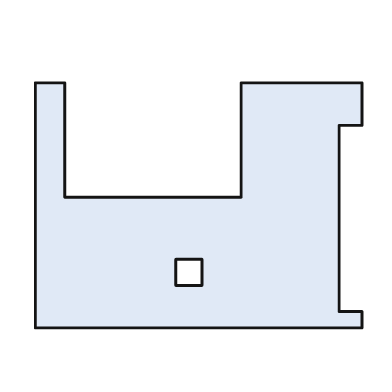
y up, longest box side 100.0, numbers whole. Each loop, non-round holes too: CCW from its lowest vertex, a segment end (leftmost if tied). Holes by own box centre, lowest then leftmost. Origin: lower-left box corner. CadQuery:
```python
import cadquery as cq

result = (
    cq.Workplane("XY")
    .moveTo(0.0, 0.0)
    .lineTo(100.0, 0.0)
    .lineTo(100.0, 5.0)
    .lineTo(93.0, 5.0)
    .lineTo(93.0, 62.0)
    .lineTo(100.0, 62.0)
    .lineTo(100.0, 75.0)
    .lineTo(63.0, 75.0)
    .lineTo(63.0, 40.0)
    .lineTo(9.0, 40.0)
    .lineTo(9.0, 75.0)
    .lineTo(0.0, 75.0)
    .close()
    .moveTo(43.0, 13.0)
    .lineTo(51.0, 13.0)
    .lineTo(51.0, 21.0)
    .lineTo(43.0, 21.0)
    .close()
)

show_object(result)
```